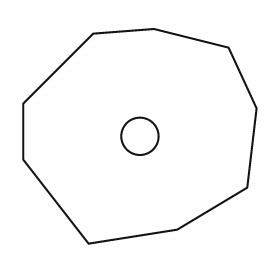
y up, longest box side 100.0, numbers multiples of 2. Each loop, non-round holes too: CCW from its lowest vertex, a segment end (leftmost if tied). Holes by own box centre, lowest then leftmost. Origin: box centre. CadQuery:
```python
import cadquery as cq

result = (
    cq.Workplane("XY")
    .moveTo(-22.0, -46.0)
    .lineTo(16.0, -40.0)
    .lineTo(46.0, -22.0)
    .lineTo(50.0, 12.0)
    .lineTo(38.0, 38.0)
    .lineTo(6.0, 46.0)
    .lineTo(-20.0, 44.0)
    .lineTo(-50.0, 14.0)
    .lineTo(-50.0, -10.0)
    .close()
    .moveTo(0.0, 0.0)
    .circle(8.0)
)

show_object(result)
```